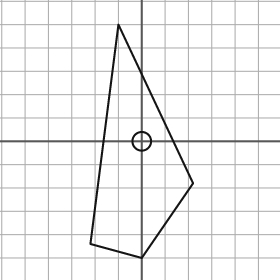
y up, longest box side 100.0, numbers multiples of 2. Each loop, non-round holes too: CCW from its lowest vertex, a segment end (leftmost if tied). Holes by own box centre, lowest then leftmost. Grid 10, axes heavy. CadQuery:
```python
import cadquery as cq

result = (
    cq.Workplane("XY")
    .moveTo(0.0, -50.0)
    .lineTo(22.0, -18.0)
    .lineTo(-10.0, 50.0)
    .lineTo(-22.0, -44.0)
    .close()
    .moveTo(0.0, 0.0)
    .circle(4.0)
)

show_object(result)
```